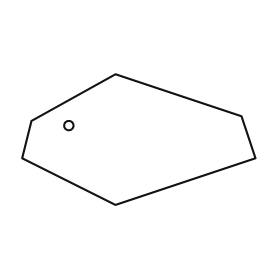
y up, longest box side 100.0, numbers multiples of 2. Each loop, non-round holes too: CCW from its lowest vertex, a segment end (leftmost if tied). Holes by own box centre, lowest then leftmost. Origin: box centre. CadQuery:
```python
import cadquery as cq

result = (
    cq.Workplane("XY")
    .moveTo(-10.0, -28.0)
    .lineTo(50.0, -8.0)
    .lineTo(44.0, 10.0)
    .lineTo(-10.0, 28.0)
    .lineTo(-46.0, 8.0)
    .lineTo(-50.0, -8.0)
    .close()
    .moveTo(-30.0, 6.0)
    .circle(2.0)
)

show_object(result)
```